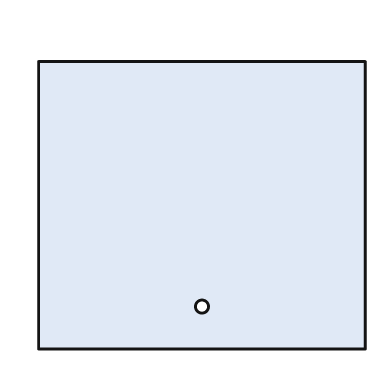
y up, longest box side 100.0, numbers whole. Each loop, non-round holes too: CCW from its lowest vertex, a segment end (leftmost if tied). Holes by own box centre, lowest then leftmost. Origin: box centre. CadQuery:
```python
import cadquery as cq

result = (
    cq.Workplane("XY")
    .moveTo(-50.0, -44.0)
    .lineTo(50.0, -44.0)
    .lineTo(50.0, 44.0)
    .lineTo(-50.0, 44.0)
    .close()
    .moveTo(0.0, -31.0)
    .circle(2.0)
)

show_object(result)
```